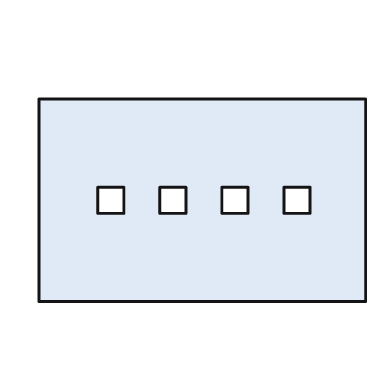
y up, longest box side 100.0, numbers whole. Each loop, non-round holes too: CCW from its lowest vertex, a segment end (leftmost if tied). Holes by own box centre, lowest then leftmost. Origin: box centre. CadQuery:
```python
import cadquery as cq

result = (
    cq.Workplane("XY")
    .moveTo(-50.0, -31.0)
    .lineTo(50.0, -31.0)
    .lineTo(50.0, 31.0)
    .lineTo(-50.0, 31.0)
    .close()
    .moveTo(-32.0, -4.0)
    .lineTo(-24.0, -4.0)
    .lineTo(-24.0, 4.0)
    .lineTo(-32.0, 4.0)
    .close()
    .moveTo(-13.0, -4.0)
    .lineTo(-5.0, -4.0)
    .lineTo(-5.0, 4.0)
    .lineTo(-13.0, 4.0)
    .close()
    .moveTo(6.0, -4.0)
    .lineTo(14.0, -4.0)
    .lineTo(14.0, 4.0)
    .lineTo(6.0, 4.0)
    .close()
    .moveTo(25.0, -4.0)
    .lineTo(33.0, -4.0)
    .lineTo(33.0, 4.0)
    .lineTo(25.0, 4.0)
    .close()
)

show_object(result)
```